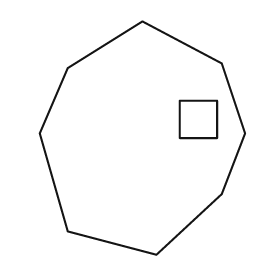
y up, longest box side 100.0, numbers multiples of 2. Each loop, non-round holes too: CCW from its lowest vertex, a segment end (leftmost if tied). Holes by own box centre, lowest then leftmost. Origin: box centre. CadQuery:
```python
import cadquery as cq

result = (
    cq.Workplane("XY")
    .moveTo(6.0, -50.0)
    .lineTo(34.0, -24.0)
    .lineTo(44.0, 2.0)
    .lineTo(34.0, 32.0)
    .lineTo(0.0, 50.0)
    .lineTo(-32.0, 30.0)
    .lineTo(-44.0, 2.0)
    .lineTo(-32.0, -40.0)
    .close()
    .moveTo(16.0, 0.0)
    .lineTo(32.0, 0.0)
    .lineTo(32.0, 16.0)
    .lineTo(16.0, 16.0)
    .close()
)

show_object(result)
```